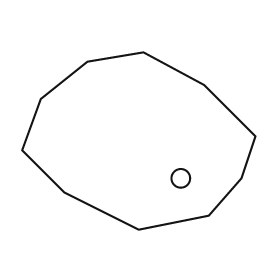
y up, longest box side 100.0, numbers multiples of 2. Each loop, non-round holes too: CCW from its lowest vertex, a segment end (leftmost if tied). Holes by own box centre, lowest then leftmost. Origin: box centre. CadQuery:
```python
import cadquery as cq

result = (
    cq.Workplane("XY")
    .moveTo(0.0, -38.0)
    .lineTo(30.0, -32.0)
    .lineTo(44.0, -16.0)
    .lineTo(50.0, 2.0)
    .lineTo(28.0, 24.0)
    .lineTo(2.0, 38.0)
    .lineTo(-22.0, 34.0)
    .lineTo(-42.0, 18.0)
    .lineTo(-50.0, -4.0)
    .lineTo(-32.0, -22.0)
    .close()
    .moveTo(18.0, -16.0)
    .circle(4.0)
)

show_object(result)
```